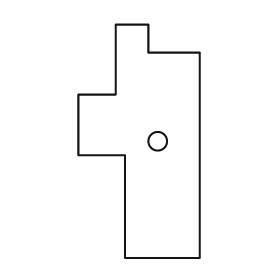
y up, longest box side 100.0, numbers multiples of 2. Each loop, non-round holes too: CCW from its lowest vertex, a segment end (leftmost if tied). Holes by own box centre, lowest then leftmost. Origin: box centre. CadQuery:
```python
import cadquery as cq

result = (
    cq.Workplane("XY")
    .moveTo(-6.0, -50.0)
    .lineTo(26.0, -50.0)
    .lineTo(26.0, 38.0)
    .lineTo(4.0, 38.0)
    .lineTo(4.0, 50.0)
    .lineTo(-10.0, 50.0)
    .lineTo(-10.0, 20.0)
    .lineTo(-26.0, 20.0)
    .lineTo(-26.0, -6.0)
    .lineTo(-6.0, -6.0)
    .close()
    .moveTo(8.0, 0.0)
    .circle(4.0)
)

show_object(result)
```